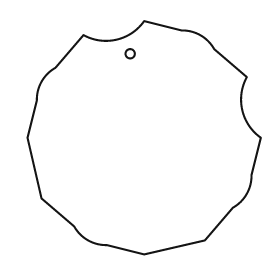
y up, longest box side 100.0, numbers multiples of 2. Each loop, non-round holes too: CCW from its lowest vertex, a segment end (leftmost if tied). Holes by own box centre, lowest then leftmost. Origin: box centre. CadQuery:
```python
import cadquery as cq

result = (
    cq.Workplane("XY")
    .moveTo(0.0, -50.0)
    .lineTo(26.0, -44.0)
    .lineTo(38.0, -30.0)
    .threePointArc((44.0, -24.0), (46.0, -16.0))
    .lineTo(50.0, 0.0)
    .threePointArc((42.0, 12.0), (44.0, 26.0))
    .lineTo(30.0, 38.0)
    .threePointArc((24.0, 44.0), (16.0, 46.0))
    .lineTo(0.0, 50.0)
    .threePointArc((-12.0, 42.0), (-26.0, 44.0))
    .lineTo(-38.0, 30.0)
    .threePointArc((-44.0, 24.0), (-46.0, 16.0))
    .lineTo(-50.0, 0.0)
    .lineTo(-44.0, -26.0)
    .lineTo(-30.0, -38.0)
    .threePointArc((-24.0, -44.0), (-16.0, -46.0))
    .close()
    .moveTo(-6.0, 36.0)
    .circle(2.0)
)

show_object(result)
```